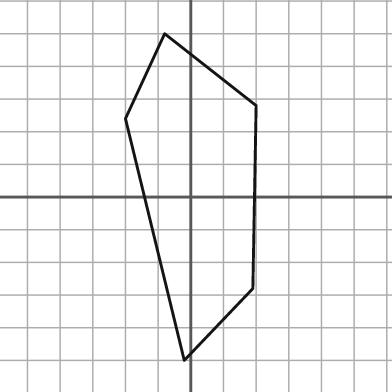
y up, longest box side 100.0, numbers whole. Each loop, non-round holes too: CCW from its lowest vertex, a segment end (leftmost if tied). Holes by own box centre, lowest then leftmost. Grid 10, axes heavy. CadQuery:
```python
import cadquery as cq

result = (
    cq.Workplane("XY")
    .moveTo(-2.0, -50.0)
    .lineTo(19.0, -28.0)
    .lineTo(20.0, 28.0)
    .lineTo(-8.0, 50.0)
    .lineTo(-20.0, 24.0)
    .close()
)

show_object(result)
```